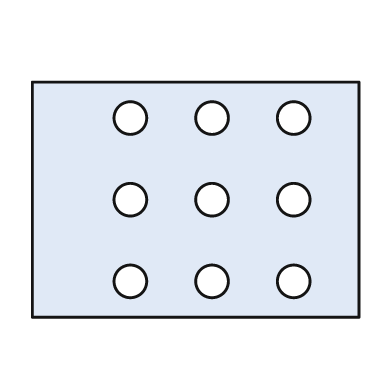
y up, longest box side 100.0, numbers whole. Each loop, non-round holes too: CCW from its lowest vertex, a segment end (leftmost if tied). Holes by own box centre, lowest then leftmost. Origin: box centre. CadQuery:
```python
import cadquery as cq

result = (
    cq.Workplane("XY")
    .moveTo(-50.0, -36.0)
    .lineTo(50.0, -36.0)
    .lineTo(50.0, 36.0)
    .lineTo(-50.0, 36.0)
    .close()
    .moveTo(-20.0, -25.0)
    .circle(5.0)
    .moveTo(5.0, -25.0)
    .circle(5.0)
    .moveTo(30.0, -25.0)
    .circle(5.0)
    .moveTo(-20.0, 0.0)
    .circle(5.0)
    .moveTo(5.0, 0.0)
    .circle(5.0)
    .moveTo(30.0, 0.0)
    .circle(5.0)
    .moveTo(-20.0, 25.0)
    .circle(5.0)
    .moveTo(5.0, 25.0)
    .circle(5.0)
    .moveTo(30.0, 25.0)
    .circle(5.0)
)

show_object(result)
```